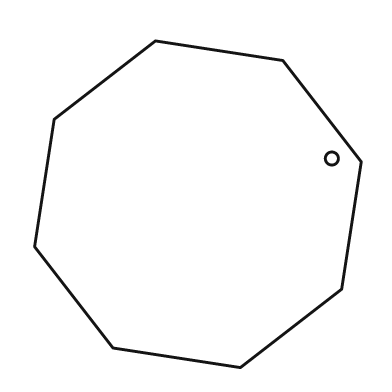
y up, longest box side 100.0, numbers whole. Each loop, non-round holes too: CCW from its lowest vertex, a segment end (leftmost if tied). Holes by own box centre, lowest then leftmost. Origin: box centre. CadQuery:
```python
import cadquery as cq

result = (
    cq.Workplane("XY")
    .moveTo(13.0, -50.0)
    .lineTo(44.0, -26.0)
    .lineTo(50.0, 13.0)
    .lineTo(26.0, 44.0)
    .lineTo(-13.0, 50.0)
    .lineTo(-44.0, 26.0)
    .lineTo(-50.0, -13.0)
    .lineTo(-26.0, -44.0)
    .close()
    .moveTo(41.0, 14.0)
    .circle(2.0)
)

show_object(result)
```